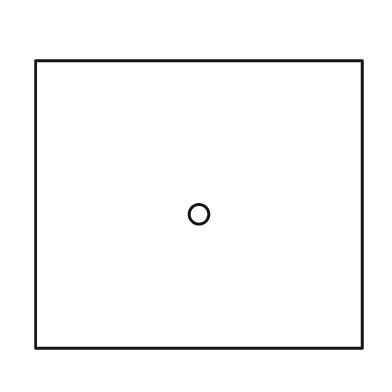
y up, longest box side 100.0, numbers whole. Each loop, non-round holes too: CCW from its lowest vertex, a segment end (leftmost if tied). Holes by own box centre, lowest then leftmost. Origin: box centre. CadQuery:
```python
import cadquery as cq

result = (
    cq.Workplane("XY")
    .moveTo(-50.0, -44.0)
    .lineTo(50.0, -44.0)
    .lineTo(50.0, 44.0)
    .lineTo(-50.0, 44.0)
    .close()
    .moveTo(0.0, -3.0)
    .circle(3.0)
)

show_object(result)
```